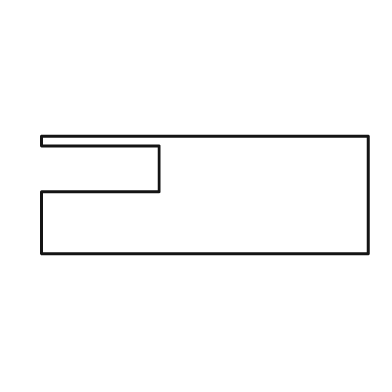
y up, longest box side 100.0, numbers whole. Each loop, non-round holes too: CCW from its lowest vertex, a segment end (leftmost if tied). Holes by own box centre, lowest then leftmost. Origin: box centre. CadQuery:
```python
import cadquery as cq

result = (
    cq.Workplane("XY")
    .moveTo(-50.0, -18.0)
    .lineTo(50.0, -18.0)
    .lineTo(50.0, 18.0)
    .lineTo(-50.0, 18.0)
    .lineTo(-50.0, 15.0)
    .lineTo(-14.0, 15.0)
    .lineTo(-14.0, 1.0)
    .lineTo(-50.0, 1.0)
    .close()
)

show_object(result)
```